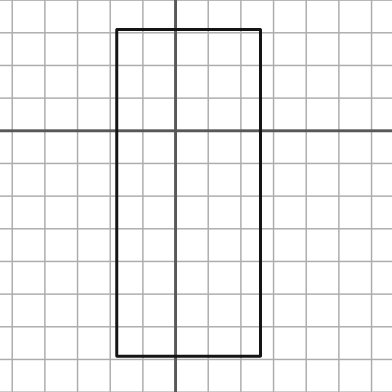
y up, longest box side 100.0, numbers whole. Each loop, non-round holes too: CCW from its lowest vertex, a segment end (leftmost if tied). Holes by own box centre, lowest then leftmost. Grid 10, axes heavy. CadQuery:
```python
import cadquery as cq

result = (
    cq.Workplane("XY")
    .moveTo(-18.0, -69.0)
    .lineTo(26.0, -69.0)
    .lineTo(26.0, 31.0)
    .lineTo(-18.0, 31.0)
    .close()
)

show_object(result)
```